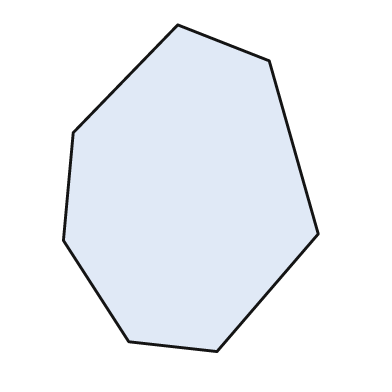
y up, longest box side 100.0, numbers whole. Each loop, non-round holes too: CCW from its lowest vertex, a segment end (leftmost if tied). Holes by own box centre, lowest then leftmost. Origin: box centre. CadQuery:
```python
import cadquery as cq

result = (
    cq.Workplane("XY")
    .moveTo(8.0, -50.0)
    .lineTo(39.0, -14.0)
    .lineTo(24.0, 39.0)
    .lineTo(-4.0, 50.0)
    .lineTo(-36.0, 17.0)
    .lineTo(-39.0, -16.0)
    .lineTo(-19.0, -47.0)
    .close()
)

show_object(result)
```